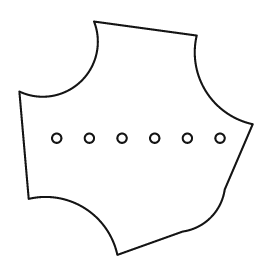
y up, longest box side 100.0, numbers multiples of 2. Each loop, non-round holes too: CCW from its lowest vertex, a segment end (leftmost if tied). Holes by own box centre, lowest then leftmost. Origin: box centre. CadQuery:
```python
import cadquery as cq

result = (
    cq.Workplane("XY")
    .moveTo(-8.0, -50.0)
    .lineTo(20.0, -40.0)
    .threePointArc((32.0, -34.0), (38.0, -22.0))
    .lineTo(50.0, 6.0)
    .threePointArc((30.0, 20.0), (26.0, 44.0))
    .lineTo(-18.0, 50.0)
    .threePointArc((-24.0, 24.0), (-50.0, 20.0))
    .lineTo(-46.0, -26.0)
    .threePointArc((-22.0, -30.0), (-8.0, -50.0))
    .close()
    .moveTo(-34.0, 0.0)
    .circle(2.0)
    .moveTo(-20.0, 0.0)
    .circle(2.0)
    .moveTo(-6.0, 0.0)
    .circle(2.0)
    .moveTo(8.0, 0.0)
    .circle(2.0)
    .moveTo(22.0, 0.0)
    .circle(2.0)
    .moveTo(36.0, 0.0)
    .circle(2.0)
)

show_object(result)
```